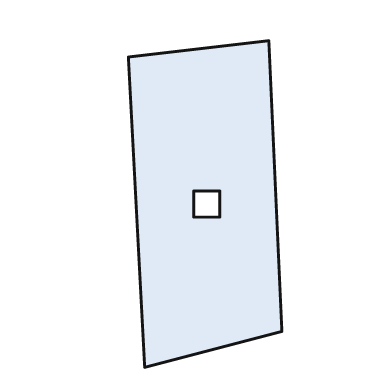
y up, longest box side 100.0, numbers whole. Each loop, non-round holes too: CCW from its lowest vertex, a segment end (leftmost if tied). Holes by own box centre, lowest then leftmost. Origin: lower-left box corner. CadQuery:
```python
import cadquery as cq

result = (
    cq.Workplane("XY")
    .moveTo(5.0, 0.0)
    .lineTo(47.0, 11.0)
    .lineTo(43.0, 100.0)
    .lineTo(0.0, 95.0)
    .close()
    .moveTo(20.0, 46.0)
    .lineTo(28.0, 46.0)
    .lineTo(28.0, 54.0)
    .lineTo(20.0, 54.0)
    .close()
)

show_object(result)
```